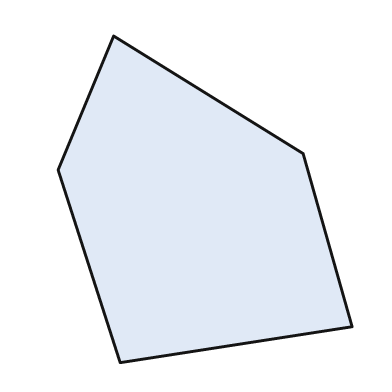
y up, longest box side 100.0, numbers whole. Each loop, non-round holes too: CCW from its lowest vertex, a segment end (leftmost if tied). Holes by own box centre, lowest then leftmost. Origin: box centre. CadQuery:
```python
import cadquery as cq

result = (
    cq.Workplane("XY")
    .moveTo(-26.0, -50.0)
    .lineTo(45.0, -39.0)
    .lineTo(30.0, 14.0)
    .lineTo(-28.0, 50.0)
    .lineTo(-45.0, 9.0)
    .close()
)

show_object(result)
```